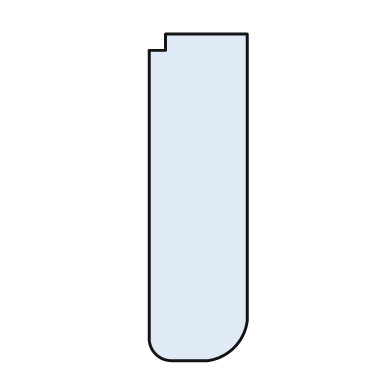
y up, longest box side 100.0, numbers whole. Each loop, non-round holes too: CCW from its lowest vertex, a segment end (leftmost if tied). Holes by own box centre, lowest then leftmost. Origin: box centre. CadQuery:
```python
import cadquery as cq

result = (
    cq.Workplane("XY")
    .moveTo(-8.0, -50.0)
    .lineTo(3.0, -50.0)
    .threePointArc((11.0, -46.0), (15.0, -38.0))
    .lineTo(15.0, 50.0)
    .lineTo(-10.0, 50.0)
    .lineTo(-10.0, 45.0)
    .lineTo(-15.0, 45.0)
    .lineTo(-15.0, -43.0)
    .threePointArc((-13.0, -48.0), (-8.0, -50.0))
    .close()
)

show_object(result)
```